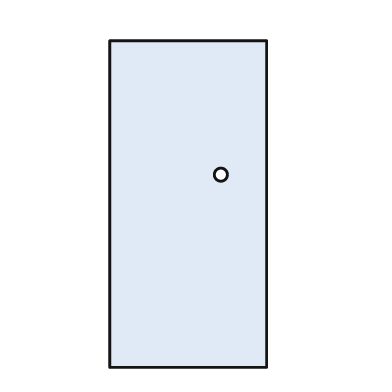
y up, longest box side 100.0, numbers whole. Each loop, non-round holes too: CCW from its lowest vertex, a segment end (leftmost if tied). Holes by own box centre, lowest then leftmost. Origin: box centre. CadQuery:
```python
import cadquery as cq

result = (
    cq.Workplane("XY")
    .moveTo(-24.0, -50.0)
    .lineTo(24.0, -50.0)
    .lineTo(24.0, 50.0)
    .lineTo(-24.0, 50.0)
    .close()
    .moveTo(10.0, 9.0)
    .circle(2.0)
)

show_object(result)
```